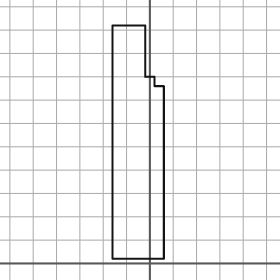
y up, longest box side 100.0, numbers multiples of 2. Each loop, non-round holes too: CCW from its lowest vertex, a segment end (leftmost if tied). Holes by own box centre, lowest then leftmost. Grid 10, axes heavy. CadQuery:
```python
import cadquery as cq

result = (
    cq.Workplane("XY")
    .moveTo(-16.0, 2.0)
    .lineTo(6.0, 2.0)
    .lineTo(6.0, 76.0)
    .lineTo(2.0, 76.0)
    .lineTo(2.0, 80.0)
    .lineTo(-2.0, 80.0)
    .lineTo(-2.0, 102.0)
    .lineTo(-16.0, 102.0)
    .close()
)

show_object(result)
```